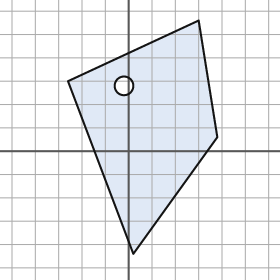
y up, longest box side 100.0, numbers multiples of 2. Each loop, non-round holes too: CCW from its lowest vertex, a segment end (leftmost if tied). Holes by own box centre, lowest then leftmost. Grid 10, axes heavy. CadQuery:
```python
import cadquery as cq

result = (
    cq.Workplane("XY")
    .moveTo(2.0, -44.0)
    .lineTo(38.0, 6.0)
    .lineTo(30.0, 56.0)
    .lineTo(-26.0, 30.0)
    .close()
    .moveTo(-2.0, 28.0)
    .circle(4.0)
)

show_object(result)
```